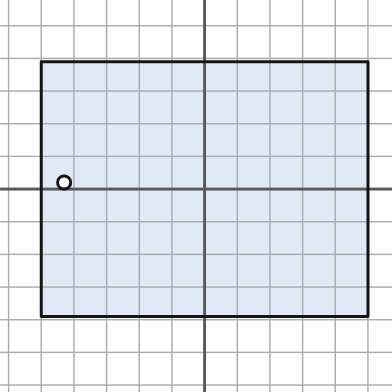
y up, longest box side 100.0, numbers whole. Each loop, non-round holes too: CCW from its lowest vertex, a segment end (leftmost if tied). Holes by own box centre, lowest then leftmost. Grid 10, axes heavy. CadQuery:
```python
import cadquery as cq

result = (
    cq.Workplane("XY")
    .moveTo(-50.0, -39.0)
    .lineTo(50.0, -39.0)
    .lineTo(50.0, 39.0)
    .lineTo(-50.0, 39.0)
    .close()
    .moveTo(-43.0, 2.0)
    .circle(2.0)
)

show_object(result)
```